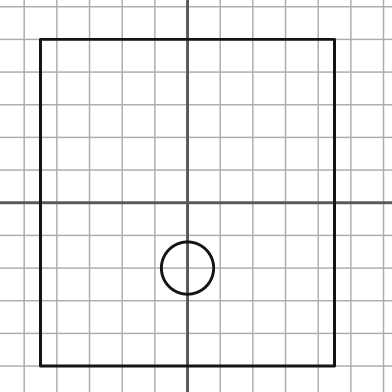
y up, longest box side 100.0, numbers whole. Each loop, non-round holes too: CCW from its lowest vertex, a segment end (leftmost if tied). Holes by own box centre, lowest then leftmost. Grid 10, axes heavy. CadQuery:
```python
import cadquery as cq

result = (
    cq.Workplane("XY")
    .moveTo(-45.0, -50.0)
    .lineTo(45.0, -50.0)
    .lineTo(45.0, 50.0)
    .lineTo(-45.0, 50.0)
    .close()
    .moveTo(0.0, -20.0)
    .circle(8.0)
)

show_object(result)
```